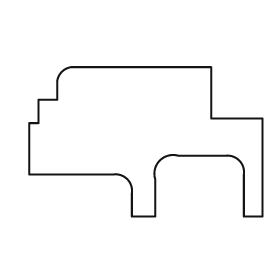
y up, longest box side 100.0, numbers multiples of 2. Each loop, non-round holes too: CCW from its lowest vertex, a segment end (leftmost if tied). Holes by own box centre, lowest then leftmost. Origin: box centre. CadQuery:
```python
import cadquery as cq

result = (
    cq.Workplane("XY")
    .moveTo(-6.0, -32.0)
    .lineTo(4.0, -32.0)
    .lineTo(4.0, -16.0)
    .threePointArc((6.0, -8.0), (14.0, -6.0))
    .lineTo(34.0, -6.0)
    .threePointArc((40.0, -8.0), (42.0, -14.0))
    .lineTo(42.0, -32.0)
    .lineTo(50.0, -32.0)
    .lineTo(50.0, 10.0)
    .lineTo(28.0, 10.0)
    .lineTo(28.0, 32.0)
    .lineTo(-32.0, 32.0)
    .threePointArc((-36.0, 30.0), (-38.0, 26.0))
    .lineTo(-38.0, 18.0)
    .lineTo(-46.0, 18.0)
    .lineTo(-46.0, 8.0)
    .lineTo(-50.0, 8.0)
    .lineTo(-50.0, -14.0)
    .lineTo(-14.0, -14.0)
    .threePointArc((-8.0, -16.0), (-6.0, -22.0))
    .close()
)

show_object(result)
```